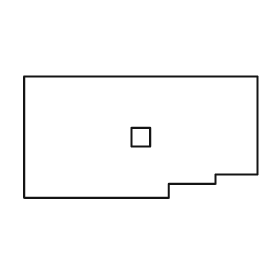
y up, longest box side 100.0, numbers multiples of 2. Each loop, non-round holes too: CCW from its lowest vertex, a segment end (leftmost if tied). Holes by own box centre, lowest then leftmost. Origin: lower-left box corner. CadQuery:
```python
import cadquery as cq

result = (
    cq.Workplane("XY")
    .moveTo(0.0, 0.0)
    .lineTo(62.0, 0.0)
    .lineTo(62.0, 6.0)
    .lineTo(82.0, 6.0)
    .lineTo(82.0, 10.0)
    .lineTo(100.0, 10.0)
    .lineTo(100.0, 52.0)
    .lineTo(0.0, 52.0)
    .close()
    .moveTo(46.0, 22.0)
    .lineTo(54.0, 22.0)
    .lineTo(54.0, 30.0)
    .lineTo(46.0, 30.0)
    .close()
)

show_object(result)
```